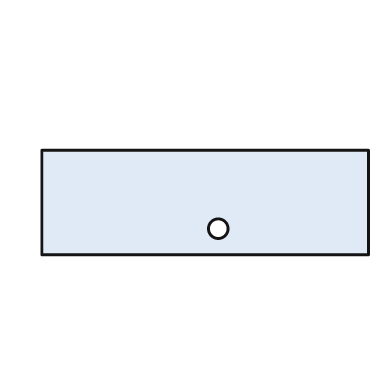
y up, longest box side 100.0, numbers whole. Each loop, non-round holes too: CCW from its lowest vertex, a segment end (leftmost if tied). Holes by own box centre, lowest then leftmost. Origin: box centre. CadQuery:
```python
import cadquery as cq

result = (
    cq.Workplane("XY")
    .moveTo(-50.0, -16.0)
    .lineTo(50.0, -16.0)
    .lineTo(50.0, 16.0)
    .lineTo(-50.0, 16.0)
    .close()
    .moveTo(4.0, -8.0)
    .circle(3.0)
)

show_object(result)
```